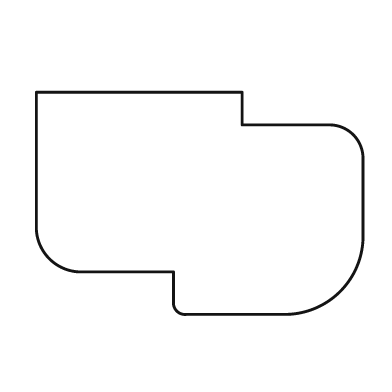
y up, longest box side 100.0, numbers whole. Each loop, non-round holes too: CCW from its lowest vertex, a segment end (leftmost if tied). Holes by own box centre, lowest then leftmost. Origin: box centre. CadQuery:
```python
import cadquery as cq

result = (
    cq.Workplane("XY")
    .moveTo(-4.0, -34.0)
    .lineTo(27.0, -34.0)
    .threePointArc((43.0, -27.0), (50.0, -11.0))
    .lineTo(50.0, 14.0)
    .threePointArc((47.0, 21.0), (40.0, 24.0))
    .lineTo(13.0, 24.0)
    .lineTo(13.0, 34.0)
    .lineTo(-50.0, 34.0)
    .lineTo(-50.0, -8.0)
    .threePointArc((-46.0, -17.0), (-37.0, -21.0))
    .lineTo(-8.0, -21.0)
    .lineTo(-8.0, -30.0)
    .threePointArc((-7.0, -33.0), (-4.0, -34.0))
    .close()
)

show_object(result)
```